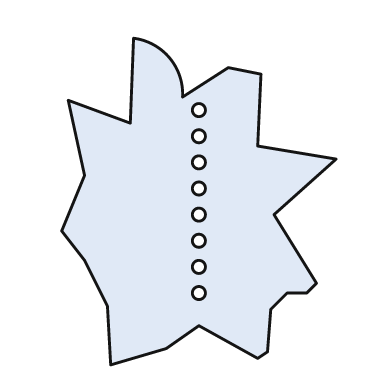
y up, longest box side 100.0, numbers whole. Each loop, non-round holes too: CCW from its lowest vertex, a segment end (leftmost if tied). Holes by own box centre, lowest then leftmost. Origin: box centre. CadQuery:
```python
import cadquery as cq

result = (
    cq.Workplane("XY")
    .moveTo(-27.0, -50.0)
    .lineTo(-10.0, -45.0)
    .lineTo(0.0, -38.0)
    .lineTo(18.0, -48.0)
    .lineTo(21.0, -46.0)
    .lineTo(22.0, -33.0)
    .lineTo(27.0, -28.0)
    .lineTo(33.0, -28.0)
    .lineTo(36.0, -25.0)
    .lineTo(23.0, -4.0)
    .lineTo(42.0, 13.0)
    .lineTo(18.0, 17.0)
    .lineTo(19.0, 39.0)
    .lineTo(9.0, 41.0)
    .lineTo(-5.0, 32.0)
    .threePointArc((-9.0, 44.0), (-20.0, 50.0))
    .lineTo(-21.0, 24.0)
    .lineTo(-40.0, 31.0)
    .lineTo(-35.0, 8.0)
    .lineTo(-42.0, -9.0)
    .lineTo(-35.0, -18.0)
    .lineTo(-28.0, -32.0)
    .close()
    .moveTo(0.0, -28.0)
    .circle(2.0)
    .moveTo(0.0, -20.0)
    .circle(2.0)
    .moveTo(0.0, -12.0)
    .circle(2.0)
    .moveTo(0.0, -4.0)
    .circle(2.0)
    .moveTo(0.0, 4.0)
    .circle(2.0)
    .moveTo(0.0, 12.0)
    .circle(2.0)
    .moveTo(0.0, 20.0)
    .circle(2.0)
    .moveTo(0.0, 28.0)
    .circle(2.0)
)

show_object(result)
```